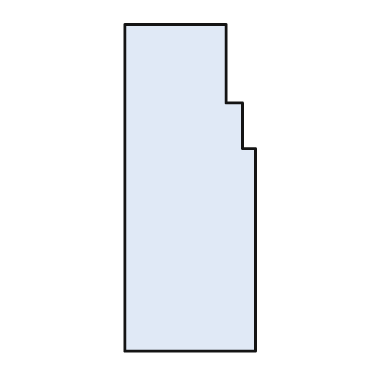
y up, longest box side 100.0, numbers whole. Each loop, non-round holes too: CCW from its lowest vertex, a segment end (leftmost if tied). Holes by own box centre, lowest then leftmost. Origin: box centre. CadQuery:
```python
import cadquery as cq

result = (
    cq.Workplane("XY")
    .moveTo(-20.0, -50.0)
    .lineTo(20.0, -50.0)
    .lineTo(20.0, 12.0)
    .lineTo(16.0, 12.0)
    .lineTo(16.0, 26.0)
    .lineTo(11.0, 26.0)
    .lineTo(11.0, 50.0)
    .lineTo(-20.0, 50.0)
    .close()
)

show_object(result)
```